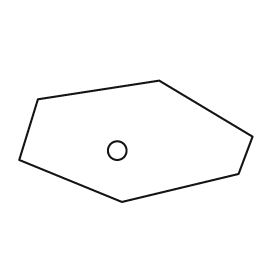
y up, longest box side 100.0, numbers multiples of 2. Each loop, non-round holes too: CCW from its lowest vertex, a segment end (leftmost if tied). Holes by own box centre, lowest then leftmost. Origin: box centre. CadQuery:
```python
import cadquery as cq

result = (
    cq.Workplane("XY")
    .moveTo(-6.0, -26.0)
    .lineTo(44.0, -14.0)
    .lineTo(50.0, 2.0)
    .lineTo(10.0, 26.0)
    .lineTo(-42.0, 18.0)
    .lineTo(-50.0, -8.0)
    .close()
    .moveTo(-8.0, -4.0)
    .circle(4.0)
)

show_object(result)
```